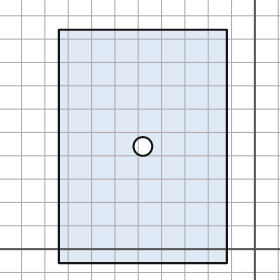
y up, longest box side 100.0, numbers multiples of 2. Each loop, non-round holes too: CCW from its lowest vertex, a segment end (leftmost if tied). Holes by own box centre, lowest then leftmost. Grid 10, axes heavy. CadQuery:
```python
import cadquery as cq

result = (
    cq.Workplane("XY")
    .moveTo(-84.0, -6.0)
    .lineTo(-12.0, -6.0)
    .lineTo(-12.0, 94.0)
    .lineTo(-84.0, 94.0)
    .close()
    .moveTo(-48.0, 44.0)
    .circle(4.0)
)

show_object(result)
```